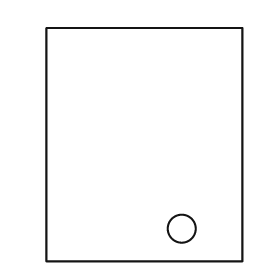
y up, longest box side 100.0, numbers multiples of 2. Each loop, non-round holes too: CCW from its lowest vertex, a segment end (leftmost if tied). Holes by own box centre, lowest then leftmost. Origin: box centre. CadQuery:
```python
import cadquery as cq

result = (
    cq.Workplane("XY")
    .moveTo(-42.0, -50.0)
    .lineTo(42.0, -50.0)
    .lineTo(42.0, 50.0)
    .lineTo(-42.0, 50.0)
    .close()
    .moveTo(16.0, -36.0)
    .circle(6.0)
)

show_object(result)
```